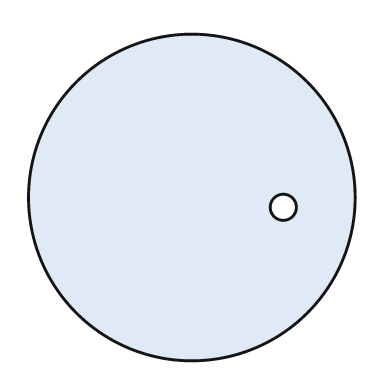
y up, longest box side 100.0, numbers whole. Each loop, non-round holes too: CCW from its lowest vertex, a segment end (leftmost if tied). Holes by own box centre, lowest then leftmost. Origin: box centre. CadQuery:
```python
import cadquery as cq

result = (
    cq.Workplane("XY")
    .moveTo(0.0, 0.0)
    .circle(50.0)
    .moveTo(28.0, -3.0)
    .circle(4.0)
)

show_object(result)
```